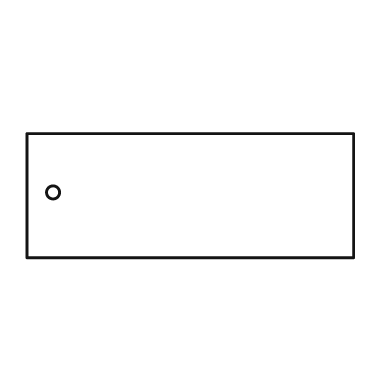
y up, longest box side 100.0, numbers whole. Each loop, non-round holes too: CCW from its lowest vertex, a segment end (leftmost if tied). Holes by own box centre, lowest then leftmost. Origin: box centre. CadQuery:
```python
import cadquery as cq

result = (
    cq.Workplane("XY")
    .moveTo(-50.0, -19.0)
    .lineTo(50.0, -19.0)
    .lineTo(50.0, 19.0)
    .lineTo(-50.0, 19.0)
    .close()
    .moveTo(-42.0, 1.0)
    .circle(2.0)
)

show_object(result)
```